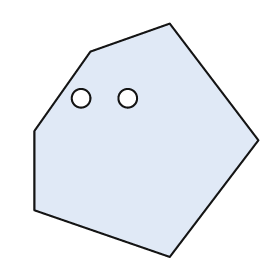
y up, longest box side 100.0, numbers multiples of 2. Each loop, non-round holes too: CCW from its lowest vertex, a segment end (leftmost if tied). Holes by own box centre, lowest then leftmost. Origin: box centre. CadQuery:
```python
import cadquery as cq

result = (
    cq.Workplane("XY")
    .moveTo(10.0, -50.0)
    .lineTo(48.0, 0.0)
    .lineTo(10.0, 50.0)
    .lineTo(-24.0, 38.0)
    .lineTo(-48.0, 4.0)
    .lineTo(-48.0, -30.0)
    .close()
    .moveTo(-28.0, 18.0)
    .circle(4.0)
    .moveTo(-8.0, 18.0)
    .circle(4.0)
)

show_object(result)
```